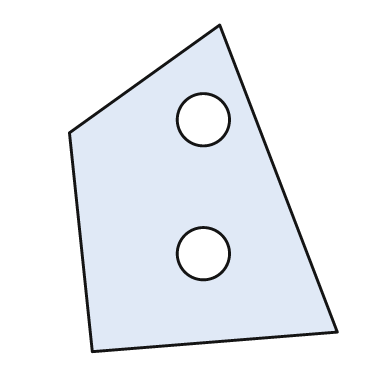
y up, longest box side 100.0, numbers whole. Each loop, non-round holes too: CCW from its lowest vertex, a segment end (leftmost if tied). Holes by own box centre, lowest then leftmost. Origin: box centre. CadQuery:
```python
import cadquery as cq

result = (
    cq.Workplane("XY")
    .moveTo(-34.0, -50.0)
    .lineTo(41.0, -44.0)
    .lineTo(5.0, 50.0)
    .lineTo(-41.0, 17.0)
    .close()
    .moveTo(0.0, -20.0)
    .circle(8.0)
    .moveTo(0.0, 21.0)
    .circle(8.0)
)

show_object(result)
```